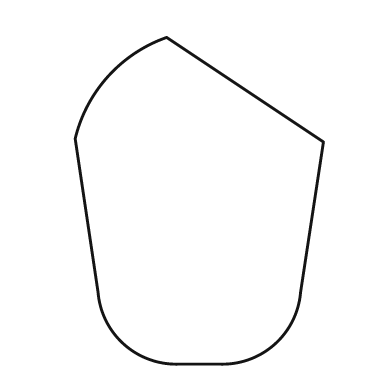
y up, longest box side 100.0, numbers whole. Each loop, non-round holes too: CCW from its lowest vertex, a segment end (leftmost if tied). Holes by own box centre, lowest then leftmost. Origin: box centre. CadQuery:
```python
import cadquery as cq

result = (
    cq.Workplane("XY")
    .moveTo(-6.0, -50.0)
    .lineTo(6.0, -50.0)
    .threePointArc((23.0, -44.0), (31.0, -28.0))
    .lineTo(38.0, 18.0)
    .lineTo(-10.0, 50.0)
    .threePointArc((-28.0, 38.0), (-38.0, 19.0))
    .lineTo(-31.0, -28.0)
    .threePointArc((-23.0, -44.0), (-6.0, -50.0))
    .close()
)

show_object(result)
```